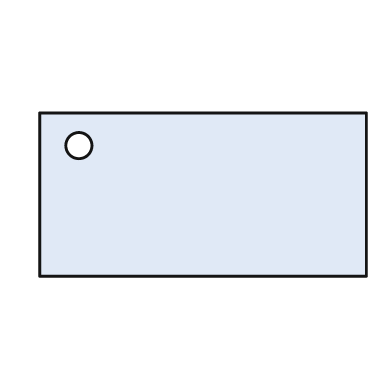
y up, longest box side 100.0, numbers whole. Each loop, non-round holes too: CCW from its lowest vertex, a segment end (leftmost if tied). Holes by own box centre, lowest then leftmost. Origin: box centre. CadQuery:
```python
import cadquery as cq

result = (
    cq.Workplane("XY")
    .moveTo(-50.0, -25.0)
    .lineTo(50.0, -25.0)
    .lineTo(50.0, 25.0)
    .lineTo(-50.0, 25.0)
    .close()
    .moveTo(-38.0, 15.0)
    .circle(4.0)
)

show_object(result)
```